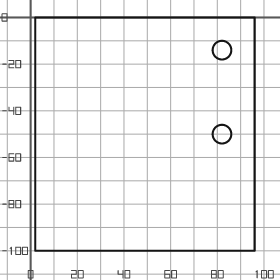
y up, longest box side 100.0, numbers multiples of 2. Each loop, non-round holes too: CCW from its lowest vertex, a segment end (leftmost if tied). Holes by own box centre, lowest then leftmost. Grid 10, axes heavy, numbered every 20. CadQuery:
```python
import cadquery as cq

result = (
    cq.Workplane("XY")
    .moveTo(2.0, -100.0)
    .lineTo(96.0, -100.0)
    .lineTo(96.0, 0.0)
    .lineTo(2.0, 0.0)
    .close()
    .moveTo(82.0, -50.0)
    .circle(4.0)
    .moveTo(82.0, -14.0)
    .circle(4.0)
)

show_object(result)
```